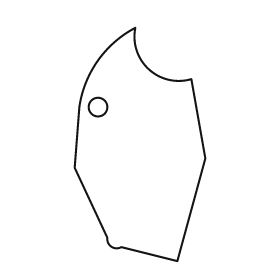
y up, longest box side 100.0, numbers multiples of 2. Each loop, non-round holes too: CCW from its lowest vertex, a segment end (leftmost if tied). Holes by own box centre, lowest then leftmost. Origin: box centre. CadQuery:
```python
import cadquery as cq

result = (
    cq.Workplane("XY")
    .moveTo(16.0, -50.0)
    .lineTo(28.0, -6.0)
    .lineTo(22.0, 28.0)
    .threePointArc((4.0, 32.0), (-2.0, 50.0))
    .threePointArc((-18.0, 36.0), (-26.0, 16.0))
    .lineTo(-28.0, -10.0)
    .lineTo(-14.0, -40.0)
    .threePointArc((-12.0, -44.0), (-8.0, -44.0))
    .close()
    .moveTo(-18.0, 16.0)
    .circle(4.0)
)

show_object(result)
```